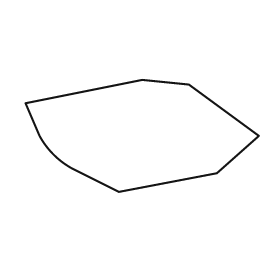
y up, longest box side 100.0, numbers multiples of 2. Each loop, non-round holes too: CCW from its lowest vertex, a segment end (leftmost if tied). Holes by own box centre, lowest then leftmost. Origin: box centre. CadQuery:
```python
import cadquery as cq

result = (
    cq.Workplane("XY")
    .moveTo(-10.0, -24.0)
    .lineTo(32.0, -16.0)
    .lineTo(50.0, 0.0)
    .lineTo(20.0, 22.0)
    .lineTo(0.0, 24.0)
    .lineTo(-50.0, 14.0)
    .lineTo(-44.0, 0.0)
    .threePointArc((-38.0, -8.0), (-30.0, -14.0))
    .close()
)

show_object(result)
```